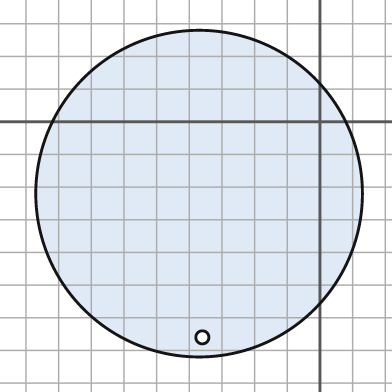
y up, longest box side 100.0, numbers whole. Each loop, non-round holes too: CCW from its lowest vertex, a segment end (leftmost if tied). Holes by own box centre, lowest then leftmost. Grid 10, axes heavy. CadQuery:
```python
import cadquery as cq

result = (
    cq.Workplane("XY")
    .moveTo(-37.0, -22.0)
    .circle(50.0)
    .moveTo(-36.0, -66.0)
    .circle(2.0)
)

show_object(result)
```